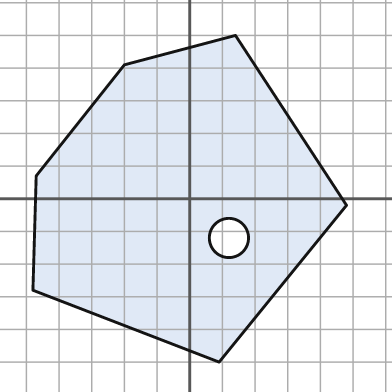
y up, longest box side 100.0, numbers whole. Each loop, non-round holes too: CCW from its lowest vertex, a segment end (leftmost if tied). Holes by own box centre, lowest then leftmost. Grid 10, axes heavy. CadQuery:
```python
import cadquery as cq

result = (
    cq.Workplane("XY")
    .moveTo(9.0, -50.0)
    .lineTo(48.0, -2.0)
    .lineTo(14.0, 50.0)
    .lineTo(-20.0, 41.0)
    .lineTo(-47.0, 7.0)
    .lineTo(-48.0, -28.0)
    .close()
    .moveTo(12.0, -12.0)
    .circle(6.0)
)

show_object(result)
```